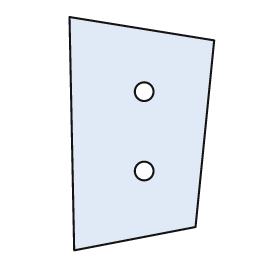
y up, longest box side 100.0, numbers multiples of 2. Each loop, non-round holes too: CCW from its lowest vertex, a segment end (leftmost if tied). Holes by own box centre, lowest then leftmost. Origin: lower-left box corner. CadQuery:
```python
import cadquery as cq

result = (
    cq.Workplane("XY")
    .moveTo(2.0, 0.0)
    .lineTo(54.0, 10.0)
    .lineTo(62.0, 90.0)
    .lineTo(0.0, 100.0)
    .close()
    .moveTo(32.0, 34.0)
    .circle(4.0)
    .moveTo(32.0, 68.0)
    .circle(4.0)
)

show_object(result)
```